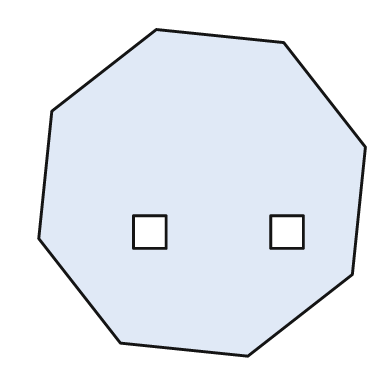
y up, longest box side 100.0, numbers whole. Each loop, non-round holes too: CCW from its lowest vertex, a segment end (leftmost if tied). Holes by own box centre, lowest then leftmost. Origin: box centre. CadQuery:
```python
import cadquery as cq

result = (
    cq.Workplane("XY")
    .moveTo(14.0, -50.0)
    .lineTo(46.0, -25.0)
    .lineTo(50.0, 14.0)
    .lineTo(25.0, 46.0)
    .lineTo(-14.0, 50.0)
    .lineTo(-46.0, 25.0)
    .lineTo(-50.0, -14.0)
    .lineTo(-25.0, -46.0)
    .close()
    .moveTo(-21.0, -17.0)
    .lineTo(-11.0, -17.0)
    .lineTo(-11.0, -7.0)
    .lineTo(-21.0, -7.0)
    .close()
    .moveTo(21.0, -17.0)
    .lineTo(31.0, -17.0)
    .lineTo(31.0, -7.0)
    .lineTo(21.0, -7.0)
    .close()
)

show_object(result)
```